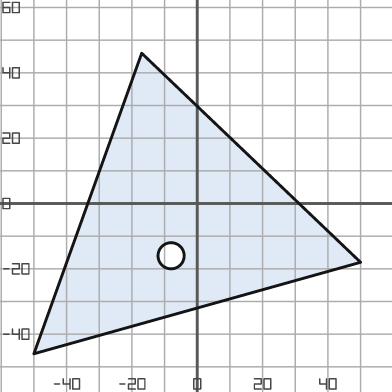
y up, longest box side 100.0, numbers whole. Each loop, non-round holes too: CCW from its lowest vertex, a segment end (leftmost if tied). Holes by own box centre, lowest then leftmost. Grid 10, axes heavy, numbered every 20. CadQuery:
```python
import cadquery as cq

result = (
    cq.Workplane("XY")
    .moveTo(-50.0, -46.0)
    .lineTo(50.0, -18.0)
    .lineTo(-17.0, 46.0)
    .close()
    .moveTo(-8.0, -16.0)
    .circle(4.0)
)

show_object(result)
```